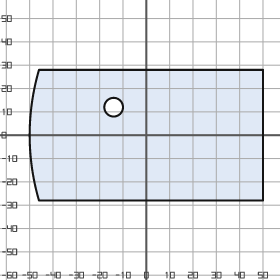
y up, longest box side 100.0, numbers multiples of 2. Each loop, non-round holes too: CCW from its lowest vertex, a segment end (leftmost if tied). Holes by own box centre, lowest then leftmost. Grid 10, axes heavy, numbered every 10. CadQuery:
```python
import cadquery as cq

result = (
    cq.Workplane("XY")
    .moveTo(-46.0, -28.0)
    .lineTo(50.0, -28.0)
    .lineTo(50.0, 28.0)
    .lineTo(-46.0, 28.0)
    .threePointArc((-50.0, 0.0), (-46.0, -28.0))
    .close()
    .moveTo(-14.0, 12.0)
    .circle(4.0)
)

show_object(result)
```